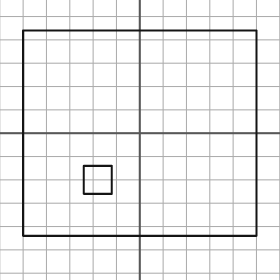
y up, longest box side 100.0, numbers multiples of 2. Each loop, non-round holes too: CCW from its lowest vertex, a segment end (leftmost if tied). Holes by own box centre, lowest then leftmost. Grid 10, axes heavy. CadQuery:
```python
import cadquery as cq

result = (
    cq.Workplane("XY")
    .moveTo(-50.0, -44.0)
    .lineTo(50.0, -44.0)
    .lineTo(50.0, 44.0)
    .lineTo(-50.0, 44.0)
    .close()
    .moveTo(-24.0, -26.0)
    .lineTo(-12.0, -26.0)
    .lineTo(-12.0, -14.0)
    .lineTo(-24.0, -14.0)
    .close()
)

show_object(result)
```